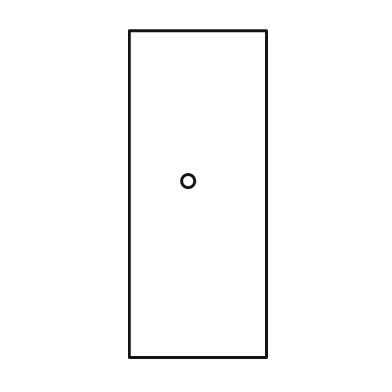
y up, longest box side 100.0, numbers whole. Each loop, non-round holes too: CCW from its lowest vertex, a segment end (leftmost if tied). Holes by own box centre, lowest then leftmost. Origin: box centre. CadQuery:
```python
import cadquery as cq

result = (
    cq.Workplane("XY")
    .moveTo(-21.0, -50.0)
    .lineTo(21.0, -50.0)
    .lineTo(21.0, 50.0)
    .lineTo(-21.0, 50.0)
    .close()
    .moveTo(-3.0, 4.0)
    .circle(2.0)
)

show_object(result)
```